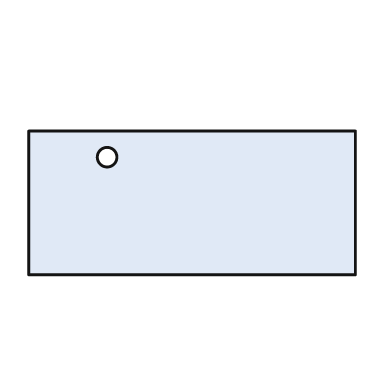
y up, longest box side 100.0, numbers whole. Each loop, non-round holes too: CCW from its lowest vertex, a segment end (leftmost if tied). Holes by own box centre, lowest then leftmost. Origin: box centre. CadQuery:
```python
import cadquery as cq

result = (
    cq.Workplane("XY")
    .moveTo(-50.0, -22.0)
    .lineTo(50.0, -22.0)
    .lineTo(50.0, 22.0)
    .lineTo(-50.0, 22.0)
    .close()
    .moveTo(-26.0, 14.0)
    .circle(3.0)
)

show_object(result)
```